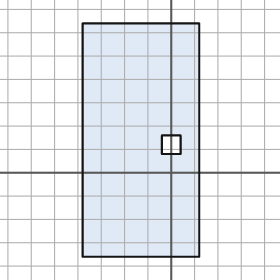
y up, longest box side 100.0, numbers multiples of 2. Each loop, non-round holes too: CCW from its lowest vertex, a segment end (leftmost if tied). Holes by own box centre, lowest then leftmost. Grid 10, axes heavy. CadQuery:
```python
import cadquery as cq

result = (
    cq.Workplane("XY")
    .moveTo(-38.0, -36.0)
    .lineTo(12.0, -36.0)
    .lineTo(12.0, 64.0)
    .lineTo(-38.0, 64.0)
    .close()
    .moveTo(-4.0, 8.0)
    .lineTo(4.0, 8.0)
    .lineTo(4.0, 16.0)
    .lineTo(-4.0, 16.0)
    .close()
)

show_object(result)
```